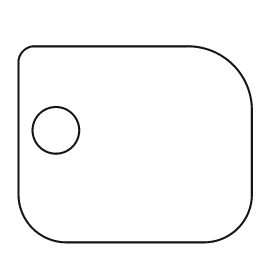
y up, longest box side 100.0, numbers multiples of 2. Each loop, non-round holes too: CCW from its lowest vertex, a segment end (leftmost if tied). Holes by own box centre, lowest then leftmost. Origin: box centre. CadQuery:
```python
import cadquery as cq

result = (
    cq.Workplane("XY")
    .moveTo(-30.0, -42.0)
    .lineTo(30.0, -42.0)
    .threePointArc((44.0, -36.0), (50.0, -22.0))
    .lineTo(50.0, 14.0)
    .threePointArc((42.0, 34.0), (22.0, 42.0))
    .lineTo(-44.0, 42.0)
    .threePointArc((-48.0, 40.0), (-50.0, 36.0))
    .lineTo(-50.0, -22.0)
    .threePointArc((-44.0, -36.0), (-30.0, -42.0))
    .close()
    .moveTo(-34.0, 6.0)
    .circle(10.0)
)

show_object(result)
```